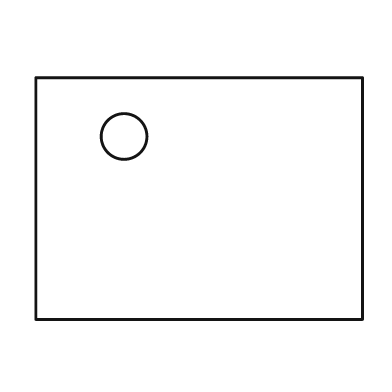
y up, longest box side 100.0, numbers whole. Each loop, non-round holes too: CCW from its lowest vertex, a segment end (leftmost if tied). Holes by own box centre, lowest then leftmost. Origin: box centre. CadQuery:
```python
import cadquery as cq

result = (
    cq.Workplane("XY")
    .moveTo(-50.0, -37.0)
    .lineTo(50.0, -37.0)
    .lineTo(50.0, 37.0)
    .lineTo(-50.0, 37.0)
    .close()
    .moveTo(-23.0, 19.0)
    .circle(7.0)
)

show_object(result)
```